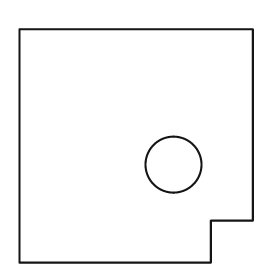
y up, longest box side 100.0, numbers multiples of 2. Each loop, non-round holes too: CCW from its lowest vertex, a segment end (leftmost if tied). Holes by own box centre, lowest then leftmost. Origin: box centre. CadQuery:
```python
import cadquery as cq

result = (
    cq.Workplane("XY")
    .moveTo(-50.0, -50.0)
    .lineTo(32.0, -50.0)
    .lineTo(32.0, -32.0)
    .lineTo(50.0, -32.0)
    .lineTo(50.0, 50.0)
    .lineTo(-50.0, 50.0)
    .close()
    .moveTo(16.0, -8.0)
    .circle(12.0)
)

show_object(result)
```